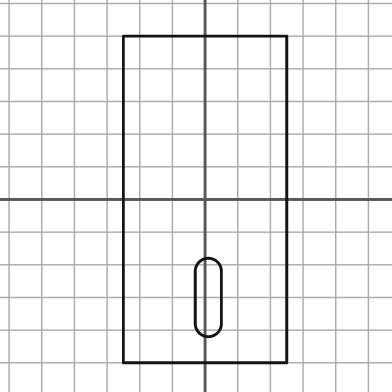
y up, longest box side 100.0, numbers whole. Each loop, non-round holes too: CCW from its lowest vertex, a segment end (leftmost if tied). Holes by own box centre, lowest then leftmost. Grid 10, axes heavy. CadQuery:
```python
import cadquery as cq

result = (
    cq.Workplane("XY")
    .moveTo(-25.0, -50.0)
    .lineTo(25.0, -50.0)
    .lineTo(25.0, 50.0)
    .lineTo(-25.0, 50.0)
    .close()
    .moveTo(-3.0, -38.0)
    .threePointArc((1.0, -42.0), (5.0, -38.0))
    .lineTo(5.0, -22.0)
    .threePointArc((1.0, -18.0), (-3.0, -22.0))
    .close()
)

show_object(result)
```